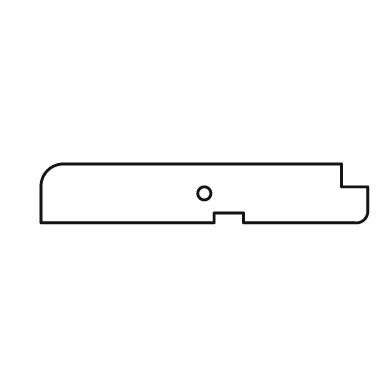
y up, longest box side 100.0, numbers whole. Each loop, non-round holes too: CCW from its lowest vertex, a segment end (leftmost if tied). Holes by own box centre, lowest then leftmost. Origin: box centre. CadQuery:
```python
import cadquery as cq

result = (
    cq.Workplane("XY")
    .moveTo(-50.0, -9.0)
    .lineTo(3.0, -9.0)
    .lineTo(3.0, -6.0)
    .lineTo(12.0, -6.0)
    .lineTo(12.0, -9.0)
    .lineTo(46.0, -9.0)
    .threePointArc((49.0, -8.0), (50.0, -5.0))
    .lineTo(50.0, 2.0)
    .lineTo(42.0, 2.0)
    .lineTo(42.0, 9.0)
    .lineTo(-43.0, 9.0)
    .threePointArc((-48.0, 7.0), (-50.0, 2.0))
    .close()
    .moveTo(0.0, 0.0)
    .circle(2.0)
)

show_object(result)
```